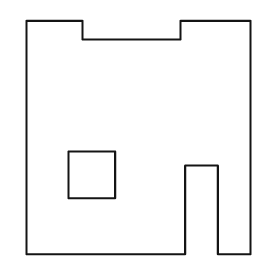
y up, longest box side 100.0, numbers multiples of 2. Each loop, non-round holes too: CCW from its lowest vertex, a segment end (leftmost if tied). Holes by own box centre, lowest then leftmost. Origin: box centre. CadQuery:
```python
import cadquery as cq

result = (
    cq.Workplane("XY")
    .moveTo(-48.0, -50.0)
    .lineTo(20.0, -50.0)
    .lineTo(20.0, -12.0)
    .lineTo(34.0, -12.0)
    .lineTo(34.0, -50.0)
    .lineTo(48.0, -50.0)
    .lineTo(48.0, 50.0)
    .lineTo(18.0, 50.0)
    .lineTo(18.0, 42.0)
    .lineTo(-24.0, 42.0)
    .lineTo(-24.0, 50.0)
    .lineTo(-48.0, 50.0)
    .close()
    .moveTo(-30.0, -26.0)
    .lineTo(-10.0, -26.0)
    .lineTo(-10.0, -6.0)
    .lineTo(-30.0, -6.0)
    .close()
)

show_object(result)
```